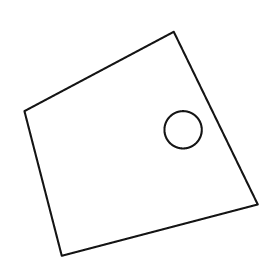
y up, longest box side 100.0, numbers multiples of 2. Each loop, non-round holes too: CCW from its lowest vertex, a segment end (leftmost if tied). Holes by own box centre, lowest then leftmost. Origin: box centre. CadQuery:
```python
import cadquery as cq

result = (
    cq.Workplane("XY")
    .moveTo(-34.0, -48.0)
    .lineTo(50.0, -26.0)
    .lineTo(14.0, 48.0)
    .lineTo(-50.0, 14.0)
    .close()
    .moveTo(18.0, 6.0)
    .circle(8.0)
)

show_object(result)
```